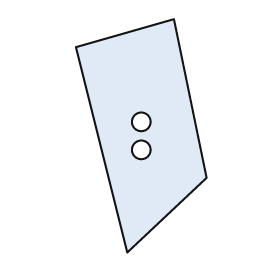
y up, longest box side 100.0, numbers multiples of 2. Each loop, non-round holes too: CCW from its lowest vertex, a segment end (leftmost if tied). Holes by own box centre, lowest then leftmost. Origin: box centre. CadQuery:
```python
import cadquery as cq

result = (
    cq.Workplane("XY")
    .moveTo(-6.0, -50.0)
    .lineTo(28.0, -18.0)
    .lineTo(14.0, 50.0)
    .lineTo(-28.0, 38.0)
    .close()
    .moveTo(0.0, -6.0)
    .circle(4.0)
    .moveTo(0.0, 6.0)
    .circle(4.0)
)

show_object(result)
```